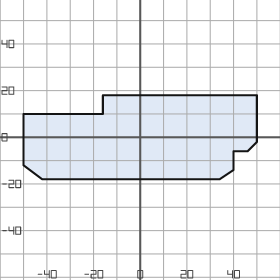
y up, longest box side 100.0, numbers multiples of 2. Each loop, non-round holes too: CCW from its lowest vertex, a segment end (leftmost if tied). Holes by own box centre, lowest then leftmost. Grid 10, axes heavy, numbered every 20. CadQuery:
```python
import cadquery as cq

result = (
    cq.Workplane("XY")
    .moveTo(-42.0, -18.0)
    .lineTo(34.0, -18.0)
    .lineTo(40.0, -14.0)
    .lineTo(40.0, -6.0)
    .lineTo(46.0, -6.0)
    .lineTo(50.0, -2.0)
    .lineTo(50.0, 18.0)
    .lineTo(-16.0, 18.0)
    .lineTo(-16.0, 10.0)
    .lineTo(-50.0, 10.0)
    .lineTo(-50.0, -12.0)
    .close()
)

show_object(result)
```